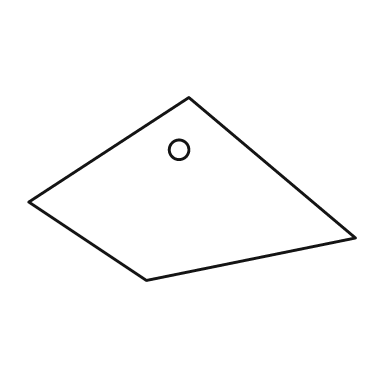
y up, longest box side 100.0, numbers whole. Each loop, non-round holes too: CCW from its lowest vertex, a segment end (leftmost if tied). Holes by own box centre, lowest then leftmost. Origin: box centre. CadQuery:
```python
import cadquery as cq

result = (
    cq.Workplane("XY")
    .moveTo(-14.0, -28.0)
    .lineTo(50.0, -15.0)
    .lineTo(-1.0, 28.0)
    .lineTo(-50.0, -4.0)
    .close()
    .moveTo(-4.0, 12.0)
    .circle(3.0)
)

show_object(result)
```